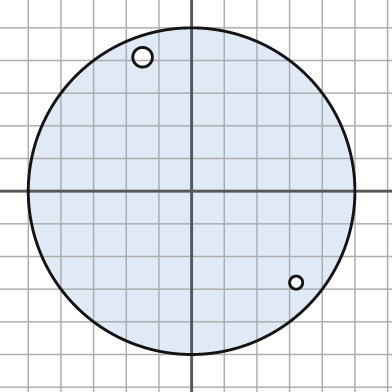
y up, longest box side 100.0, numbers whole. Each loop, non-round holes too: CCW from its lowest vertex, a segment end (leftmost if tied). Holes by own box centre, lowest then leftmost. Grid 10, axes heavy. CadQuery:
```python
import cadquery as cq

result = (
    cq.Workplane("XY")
    .moveTo(0.0, 0.0)
    .circle(50.0)
    .moveTo(32.0, -28.0)
    .circle(2.0)
    .moveTo(-15.0, 41.0)
    .circle(3.0)
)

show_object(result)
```